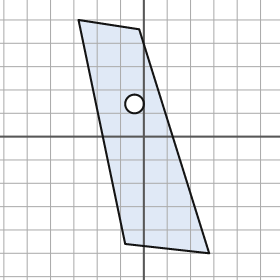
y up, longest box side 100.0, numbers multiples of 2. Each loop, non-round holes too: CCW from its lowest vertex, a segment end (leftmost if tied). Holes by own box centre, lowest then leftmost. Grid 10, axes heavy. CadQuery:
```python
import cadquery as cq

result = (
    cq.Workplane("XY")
    .moveTo(28.0, -50.0)
    .lineTo(-2.0, 46.0)
    .lineTo(-28.0, 50.0)
    .lineTo(-8.0, -46.0)
    .close()
    .moveTo(-4.0, 14.0)
    .circle(4.0)
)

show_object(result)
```